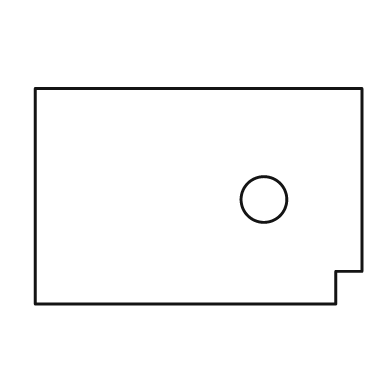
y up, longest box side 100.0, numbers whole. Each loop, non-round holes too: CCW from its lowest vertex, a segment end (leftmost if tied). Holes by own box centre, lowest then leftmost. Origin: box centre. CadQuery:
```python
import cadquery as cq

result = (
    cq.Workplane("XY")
    .moveTo(-50.0, -33.0)
    .lineTo(42.0, -33.0)
    .lineTo(42.0, -23.0)
    .lineTo(50.0, -23.0)
    .lineTo(50.0, 33.0)
    .lineTo(-50.0, 33.0)
    .close()
    .moveTo(20.0, -1.0)
    .circle(7.0)
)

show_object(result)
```